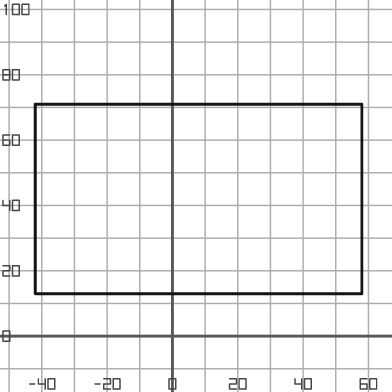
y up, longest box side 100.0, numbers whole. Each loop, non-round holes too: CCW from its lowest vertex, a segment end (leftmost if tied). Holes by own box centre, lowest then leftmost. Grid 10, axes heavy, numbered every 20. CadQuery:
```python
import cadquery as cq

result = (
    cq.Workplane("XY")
    .moveTo(-42.0, 13.0)
    .lineTo(58.0, 13.0)
    .lineTo(58.0, 71.0)
    .lineTo(-42.0, 71.0)
    .close()
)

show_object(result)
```